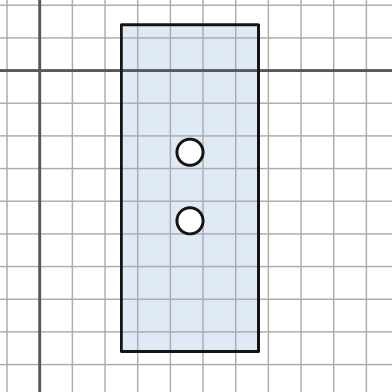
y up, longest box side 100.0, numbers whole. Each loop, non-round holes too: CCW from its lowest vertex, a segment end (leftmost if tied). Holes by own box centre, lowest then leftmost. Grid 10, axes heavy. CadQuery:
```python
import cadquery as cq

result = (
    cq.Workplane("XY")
    .moveTo(25.0, -86.0)
    .lineTo(67.0, -86.0)
    .lineTo(67.0, 14.0)
    .lineTo(25.0, 14.0)
    .close()
    .moveTo(46.0, -46.0)
    .circle(4.0)
    .moveTo(46.0, -25.0)
    .circle(4.0)
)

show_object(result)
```